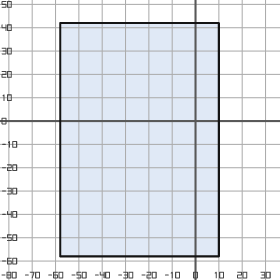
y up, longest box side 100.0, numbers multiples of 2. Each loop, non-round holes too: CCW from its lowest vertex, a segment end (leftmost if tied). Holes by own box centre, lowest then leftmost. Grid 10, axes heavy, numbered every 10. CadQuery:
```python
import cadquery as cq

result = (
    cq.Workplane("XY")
    .moveTo(-58.0, -58.0)
    .lineTo(10.0, -58.0)
    .lineTo(10.0, 42.0)
    .lineTo(-58.0, 42.0)
    .close()
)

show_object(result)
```